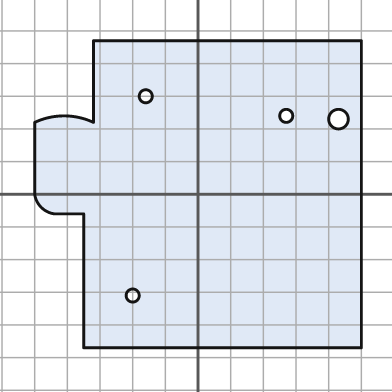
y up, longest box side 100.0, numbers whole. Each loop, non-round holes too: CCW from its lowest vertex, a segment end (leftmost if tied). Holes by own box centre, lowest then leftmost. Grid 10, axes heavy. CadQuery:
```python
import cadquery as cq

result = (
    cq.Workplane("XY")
    .moveTo(-35.0, -47.0)
    .lineTo(50.0, -47.0)
    .lineTo(50.0, 47.0)
    .lineTo(-32.0, 47.0)
    .lineTo(-32.0, 22.0)
    .threePointArc((-41.0, 24.0), (-50.0, 22.0))
    .lineTo(-50.0, 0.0)
    .threePointArc((-48.0, -4.0), (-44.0, -6.0))
    .lineTo(-35.0, -6.0)
    .close()
    .moveTo(-20.0, -31.0)
    .circle(2.0)
    .moveTo(43.0, 23.0)
    .circle(3.0)
    .moveTo(27.0, 24.0)
    .circle(2.0)
    .moveTo(-16.0, 30.0)
    .circle(2.0)
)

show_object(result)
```